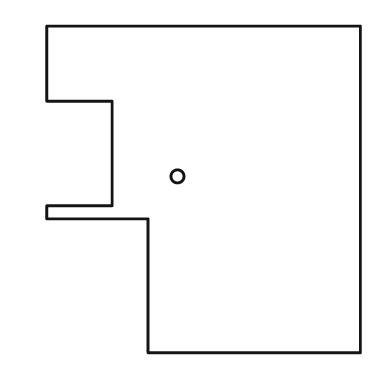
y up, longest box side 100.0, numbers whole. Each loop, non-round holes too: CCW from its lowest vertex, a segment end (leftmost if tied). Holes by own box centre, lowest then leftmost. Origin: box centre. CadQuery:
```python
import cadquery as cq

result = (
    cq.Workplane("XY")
    .moveTo(-17.0, -50.0)
    .lineTo(48.0, -50.0)
    .lineTo(48.0, 50.0)
    .lineTo(-48.0, 50.0)
    .lineTo(-48.0, 27.0)
    .lineTo(-28.0, 27.0)
    .lineTo(-28.0, -5.0)
    .lineTo(-48.0, -5.0)
    .lineTo(-48.0, -9.0)
    .lineTo(-17.0, -9.0)
    .close()
    .moveTo(-8.0, 4.0)
    .circle(2.0)
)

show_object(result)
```